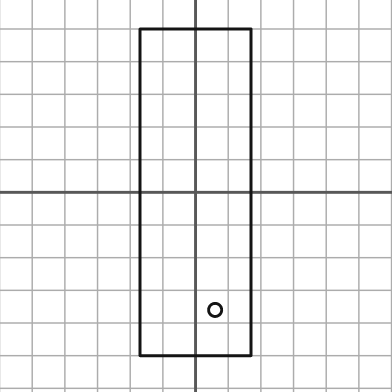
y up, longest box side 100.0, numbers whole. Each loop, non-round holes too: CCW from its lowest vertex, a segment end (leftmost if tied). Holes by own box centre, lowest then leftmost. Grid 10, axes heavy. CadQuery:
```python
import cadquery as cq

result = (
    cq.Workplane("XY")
    .moveTo(-17.0, -50.0)
    .lineTo(17.0, -50.0)
    .lineTo(17.0, 50.0)
    .lineTo(-17.0, 50.0)
    .close()
    .moveTo(6.0, -36.0)
    .circle(2.0)
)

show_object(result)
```